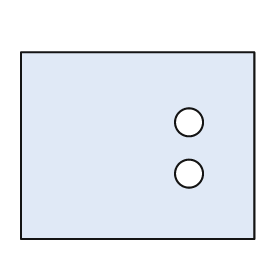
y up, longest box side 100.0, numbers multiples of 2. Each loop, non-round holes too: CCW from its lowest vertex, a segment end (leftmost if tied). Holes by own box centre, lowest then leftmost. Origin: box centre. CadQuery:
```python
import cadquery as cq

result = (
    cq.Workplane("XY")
    .moveTo(-50.0, -40.0)
    .lineTo(50.0, -40.0)
    .lineTo(50.0, 40.0)
    .lineTo(-50.0, 40.0)
    .close()
    .moveTo(22.0, -12.0)
    .circle(6.0)
    .moveTo(22.0, 10.0)
    .circle(6.0)
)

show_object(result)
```